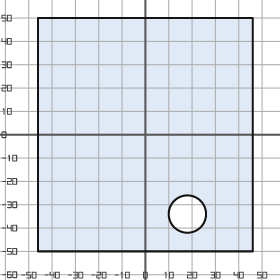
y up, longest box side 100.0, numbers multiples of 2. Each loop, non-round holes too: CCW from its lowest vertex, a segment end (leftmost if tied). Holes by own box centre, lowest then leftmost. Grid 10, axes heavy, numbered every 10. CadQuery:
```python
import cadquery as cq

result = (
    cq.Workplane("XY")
    .moveTo(-46.0, -50.0)
    .lineTo(46.0, -50.0)
    .lineTo(46.0, 50.0)
    .lineTo(-46.0, 50.0)
    .close()
    .moveTo(18.0, -34.0)
    .circle(8.0)
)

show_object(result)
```